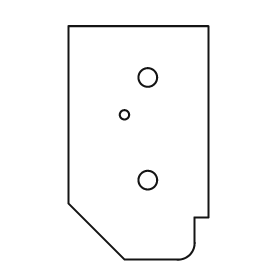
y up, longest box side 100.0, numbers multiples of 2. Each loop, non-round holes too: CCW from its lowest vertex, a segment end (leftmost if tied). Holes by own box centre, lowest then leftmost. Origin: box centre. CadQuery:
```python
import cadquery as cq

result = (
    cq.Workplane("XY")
    .moveTo(-6.0, -50.0)
    .lineTo(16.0, -50.0)
    .threePointArc((22.0, -48.0), (24.0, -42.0))
    .lineTo(24.0, -32.0)
    .lineTo(30.0, -32.0)
    .lineTo(30.0, 50.0)
    .lineTo(-30.0, 50.0)
    .lineTo(-30.0, -26.0)
    .close()
    .moveTo(4.0, -16.0)
    .circle(4.0)
    .moveTo(-6.0, 12.0)
    .circle(2.0)
    .moveTo(4.0, 28.0)
    .circle(4.0)
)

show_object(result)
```